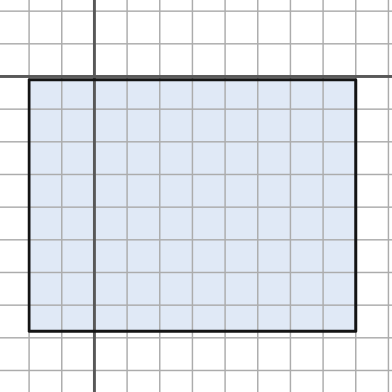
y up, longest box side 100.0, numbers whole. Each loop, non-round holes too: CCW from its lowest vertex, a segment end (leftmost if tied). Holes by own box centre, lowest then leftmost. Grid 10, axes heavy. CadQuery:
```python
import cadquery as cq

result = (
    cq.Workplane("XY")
    .moveTo(-20.0, -78.0)
    .lineTo(80.0, -78.0)
    .lineTo(80.0, -1.0)
    .lineTo(-20.0, -1.0)
    .close()
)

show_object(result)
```